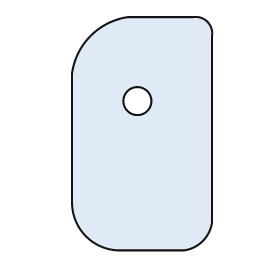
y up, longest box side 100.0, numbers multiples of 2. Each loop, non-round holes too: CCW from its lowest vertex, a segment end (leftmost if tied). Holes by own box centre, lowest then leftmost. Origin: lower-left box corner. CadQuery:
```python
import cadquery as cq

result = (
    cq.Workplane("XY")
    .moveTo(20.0, 0.0)
    .lineTo(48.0, 0.0)
    .threePointArc((56.0, 4.0), (60.0, 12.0))
    .lineTo(60.0, 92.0)
    .threePointArc((58.0, 98.0), (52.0, 100.0))
    .lineTo(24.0, 100.0)
    .threePointArc((8.0, 92.0), (0.0, 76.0))
    .lineTo(0.0, 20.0)
    .threePointArc((6.0, 6.0), (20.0, 0.0))
    .close()
    .moveTo(28.0, 64.0)
    .circle(6.0)
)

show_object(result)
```